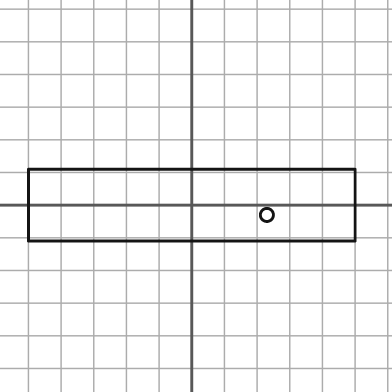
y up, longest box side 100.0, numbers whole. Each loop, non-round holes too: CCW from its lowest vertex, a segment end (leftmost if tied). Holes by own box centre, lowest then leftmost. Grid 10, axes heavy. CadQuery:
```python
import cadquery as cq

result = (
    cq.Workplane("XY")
    .moveTo(-50.0, -11.0)
    .lineTo(50.0, -11.0)
    .lineTo(50.0, 11.0)
    .lineTo(-50.0, 11.0)
    .close()
    .moveTo(23.0, -3.0)
    .circle(2.0)
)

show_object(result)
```